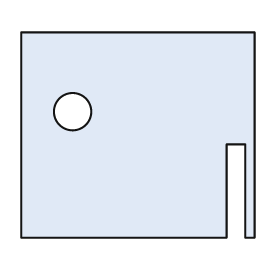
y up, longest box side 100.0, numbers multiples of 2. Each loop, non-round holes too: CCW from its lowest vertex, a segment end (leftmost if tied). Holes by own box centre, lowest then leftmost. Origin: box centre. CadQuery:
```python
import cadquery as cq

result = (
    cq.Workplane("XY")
    .moveTo(-50.0, -44.0)
    .lineTo(38.0, -44.0)
    .lineTo(38.0, -4.0)
    .lineTo(46.0, -4.0)
    .lineTo(46.0, -44.0)
    .lineTo(50.0, -44.0)
    .lineTo(50.0, 44.0)
    .lineTo(-50.0, 44.0)
    .close()
    .moveTo(-28.0, 10.0)
    .circle(8.0)
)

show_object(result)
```